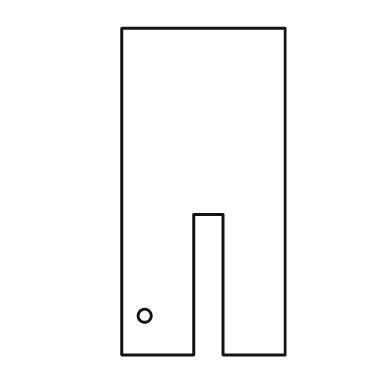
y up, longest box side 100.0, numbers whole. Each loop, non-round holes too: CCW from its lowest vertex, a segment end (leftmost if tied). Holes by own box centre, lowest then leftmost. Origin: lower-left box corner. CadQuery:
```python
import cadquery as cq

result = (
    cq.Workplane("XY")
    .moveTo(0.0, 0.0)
    .lineTo(22.0, 0.0)
    .lineTo(22.0, 43.0)
    .lineTo(31.0, 43.0)
    .lineTo(31.0, 0.0)
    .lineTo(50.0, 0.0)
    .lineTo(50.0, 100.0)
    .lineTo(0.0, 100.0)
    .close()
    .moveTo(7.0, 12.0)
    .circle(2.0)
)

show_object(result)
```